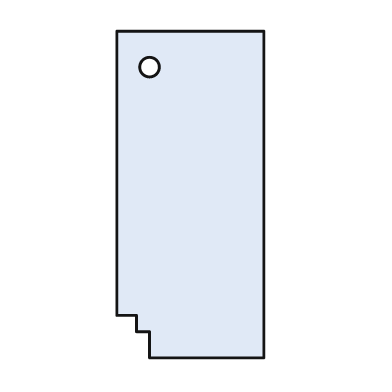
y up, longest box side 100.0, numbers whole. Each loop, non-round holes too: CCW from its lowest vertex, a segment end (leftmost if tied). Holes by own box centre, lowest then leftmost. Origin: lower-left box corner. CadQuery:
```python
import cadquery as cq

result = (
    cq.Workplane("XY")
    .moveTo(10.0, 0.0)
    .lineTo(45.0, 0.0)
    .lineTo(45.0, 100.0)
    .lineTo(0.0, 100.0)
    .lineTo(0.0, 13.0)
    .lineTo(6.0, 13.0)
    .lineTo(6.0, 8.0)
    .lineTo(10.0, 8.0)
    .close()
    .moveTo(10.0, 89.0)
    .circle(3.0)
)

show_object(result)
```